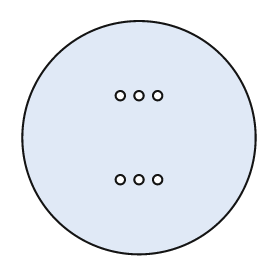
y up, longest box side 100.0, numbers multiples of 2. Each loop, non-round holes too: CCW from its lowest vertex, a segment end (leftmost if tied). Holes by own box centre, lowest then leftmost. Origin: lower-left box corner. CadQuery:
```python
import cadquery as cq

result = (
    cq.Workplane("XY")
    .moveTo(50.0, 50.0)
    .circle(50.0)
    .moveTo(42.0, 32.0)
    .circle(2.0)
    .moveTo(50.0, 32.0)
    .circle(2.0)
    .moveTo(58.0, 32.0)
    .circle(2.0)
    .moveTo(42.0, 68.0)
    .circle(2.0)
    .moveTo(50.0, 68.0)
    .circle(2.0)
    .moveTo(58.0, 68.0)
    .circle(2.0)
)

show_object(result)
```